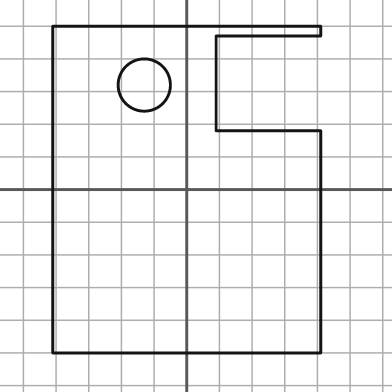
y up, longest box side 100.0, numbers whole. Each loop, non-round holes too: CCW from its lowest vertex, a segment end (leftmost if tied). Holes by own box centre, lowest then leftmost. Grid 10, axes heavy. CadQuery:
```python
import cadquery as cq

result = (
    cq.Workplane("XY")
    .moveTo(-41.0, -50.0)
    .lineTo(41.0, -50.0)
    .lineTo(41.0, 18.0)
    .lineTo(9.0, 18.0)
    .lineTo(9.0, 47.0)
    .lineTo(41.0, 47.0)
    .lineTo(41.0, 50.0)
    .lineTo(-41.0, 50.0)
    .close()
    .moveTo(-13.0, 32.0)
    .circle(8.0)
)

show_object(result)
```